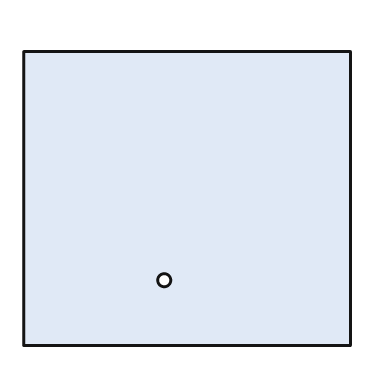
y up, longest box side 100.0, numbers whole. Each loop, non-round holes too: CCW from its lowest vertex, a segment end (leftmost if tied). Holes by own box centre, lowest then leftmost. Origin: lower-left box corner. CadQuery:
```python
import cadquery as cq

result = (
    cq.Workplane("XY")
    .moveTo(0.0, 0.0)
    .lineTo(100.0, 0.0)
    .lineTo(100.0, 90.0)
    .lineTo(0.0, 90.0)
    .close()
    .moveTo(43.0, 20.0)
    .circle(2.0)
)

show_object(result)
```